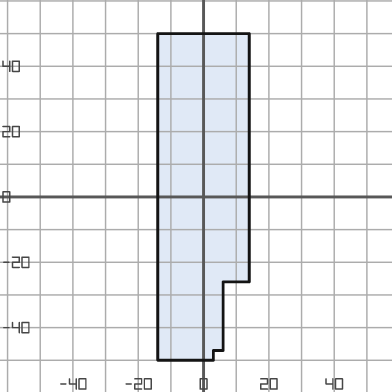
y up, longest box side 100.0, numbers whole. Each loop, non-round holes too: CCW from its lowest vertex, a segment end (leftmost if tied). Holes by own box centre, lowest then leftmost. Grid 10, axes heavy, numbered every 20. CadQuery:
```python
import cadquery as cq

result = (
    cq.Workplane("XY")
    .moveTo(-14.0, -50.0)
    .lineTo(3.0, -50.0)
    .lineTo(3.0, -47.0)
    .lineTo(6.0, -47.0)
    .lineTo(6.0, -26.0)
    .lineTo(14.0, -26.0)
    .lineTo(14.0, 50.0)
    .lineTo(-14.0, 50.0)
    .close()
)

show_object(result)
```